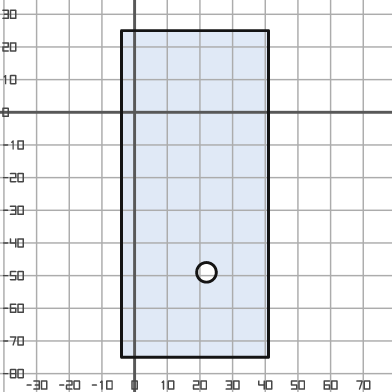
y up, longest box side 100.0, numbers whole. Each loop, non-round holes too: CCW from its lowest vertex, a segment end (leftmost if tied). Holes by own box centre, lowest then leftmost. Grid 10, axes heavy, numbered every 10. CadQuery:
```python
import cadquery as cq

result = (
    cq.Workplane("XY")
    .moveTo(-4.0, -75.0)
    .lineTo(41.0, -75.0)
    .lineTo(41.0, 25.0)
    .lineTo(-4.0, 25.0)
    .close()
    .moveTo(22.0, -49.0)
    .circle(3.0)
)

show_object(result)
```